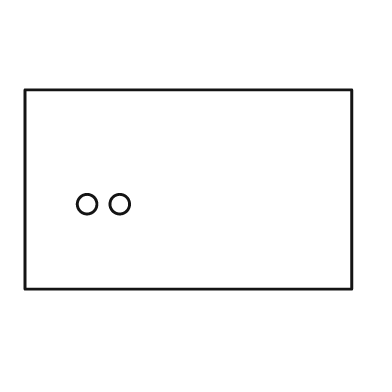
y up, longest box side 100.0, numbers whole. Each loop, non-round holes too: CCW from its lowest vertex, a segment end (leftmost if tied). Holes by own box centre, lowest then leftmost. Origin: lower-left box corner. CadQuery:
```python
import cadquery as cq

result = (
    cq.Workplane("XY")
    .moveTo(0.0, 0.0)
    .lineTo(100.0, 0.0)
    .lineTo(100.0, 61.0)
    .lineTo(0.0, 61.0)
    .close()
    .moveTo(19.0, 26.0)
    .circle(3.0)
    .moveTo(29.0, 26.0)
    .circle(3.0)
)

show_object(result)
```